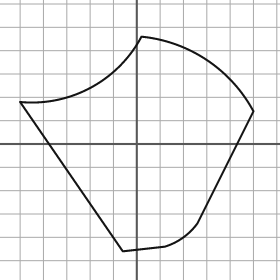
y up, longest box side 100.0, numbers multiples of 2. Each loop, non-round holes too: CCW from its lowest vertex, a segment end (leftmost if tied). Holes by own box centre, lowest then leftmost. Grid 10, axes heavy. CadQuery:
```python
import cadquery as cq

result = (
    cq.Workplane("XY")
    .moveTo(-6.0, -46.0)
    .lineTo(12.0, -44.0)
    .threePointArc((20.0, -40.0), (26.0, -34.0))
    .lineTo(50.0, 14.0)
    .threePointArc((30.0, 36.0), (2.0, 46.0))
    .threePointArc((-20.0, 24.0), (-50.0, 18.0))
    .close()
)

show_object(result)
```